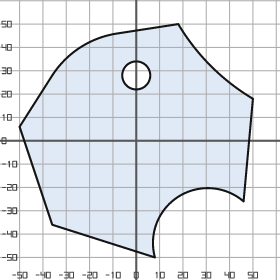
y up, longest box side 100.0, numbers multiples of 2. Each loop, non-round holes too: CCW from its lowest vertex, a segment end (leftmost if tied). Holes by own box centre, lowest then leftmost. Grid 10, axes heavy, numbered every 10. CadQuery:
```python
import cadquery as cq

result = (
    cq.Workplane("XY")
    .moveTo(8.0, -50.0)
    .threePointArc((18.0, -24.0), (46.0, -26.0))
    .lineTo(50.0, 18.0)
    .threePointArc((32.0, 32.0), (18.0, 50.0))
    .lineTo(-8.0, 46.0)
    .threePointArc((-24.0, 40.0), (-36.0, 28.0))
    .lineTo(-50.0, 6.0)
    .lineTo(-36.0, -36.0)
    .close()
    .moveTo(0.0, 28.0)
    .circle(6.0)
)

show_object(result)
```